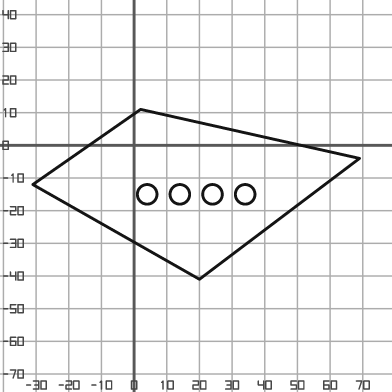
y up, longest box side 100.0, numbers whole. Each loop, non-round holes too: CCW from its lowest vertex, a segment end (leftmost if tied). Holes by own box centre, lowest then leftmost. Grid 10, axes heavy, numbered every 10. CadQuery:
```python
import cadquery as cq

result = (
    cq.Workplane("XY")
    .moveTo(20.0, -41.0)
    .lineTo(69.0, -4.0)
    .lineTo(2.0, 11.0)
    .lineTo(-31.0, -12.0)
    .close()
    .moveTo(4.0, -15.0)
    .circle(3.0)
    .moveTo(14.0, -15.0)
    .circle(3.0)
    .moveTo(24.0, -15.0)
    .circle(3.0)
    .moveTo(34.0, -15.0)
    .circle(3.0)
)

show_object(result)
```